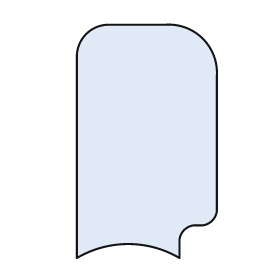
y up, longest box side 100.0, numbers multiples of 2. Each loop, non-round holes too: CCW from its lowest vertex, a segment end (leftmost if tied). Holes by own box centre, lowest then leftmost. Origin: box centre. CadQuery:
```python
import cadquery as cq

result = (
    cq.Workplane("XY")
    .moveTo(-30.0, -50.0)
    .threePointArc((-8.0, -44.0), (14.0, -50.0))
    .lineTo(14.0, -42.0)
    .threePointArc((16.0, -38.0), (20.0, -36.0))
    .lineTo(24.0, -36.0)
    .threePointArc((28.0, -34.0), (30.0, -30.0))
    .lineTo(30.0, 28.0)
    .threePointArc((24.0, 44.0), (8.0, 50.0))
    .lineTo(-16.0, 50.0)
    .threePointArc((-26.0, 46.0), (-30.0, 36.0))
    .close()
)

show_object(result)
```